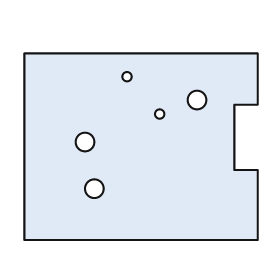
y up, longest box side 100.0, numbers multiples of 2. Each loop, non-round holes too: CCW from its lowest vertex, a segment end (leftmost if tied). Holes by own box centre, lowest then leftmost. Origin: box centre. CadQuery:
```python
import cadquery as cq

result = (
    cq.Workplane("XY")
    .moveTo(-50.0, -40.0)
    .lineTo(50.0, -40.0)
    .lineTo(50.0, -10.0)
    .lineTo(40.0, -10.0)
    .lineTo(40.0, 18.0)
    .lineTo(50.0, 18.0)
    .lineTo(50.0, 40.0)
    .lineTo(-50.0, 40.0)
    .close()
    .moveTo(-20.0, -18.0)
    .circle(4.0)
    .moveTo(-24.0, 2.0)
    .circle(4.0)
    .moveTo(8.0, 14.0)
    .circle(2.0)
    .moveTo(24.0, 20.0)
    .circle(4.0)
    .moveTo(-6.0, 30.0)
    .circle(2.0)
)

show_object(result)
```